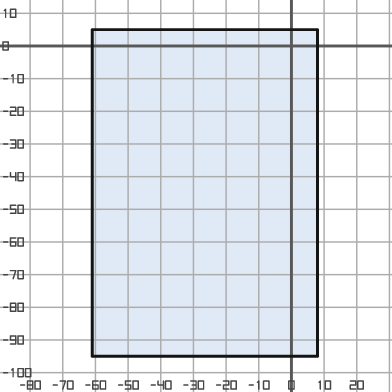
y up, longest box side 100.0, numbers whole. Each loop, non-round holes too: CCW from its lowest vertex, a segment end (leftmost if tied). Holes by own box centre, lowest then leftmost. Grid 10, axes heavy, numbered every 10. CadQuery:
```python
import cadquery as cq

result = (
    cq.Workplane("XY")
    .moveTo(-61.0, -95.0)
    .lineTo(8.0, -95.0)
    .lineTo(8.0, 5.0)
    .lineTo(-61.0, 5.0)
    .close()
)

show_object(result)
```